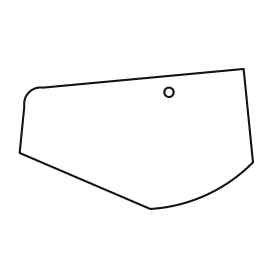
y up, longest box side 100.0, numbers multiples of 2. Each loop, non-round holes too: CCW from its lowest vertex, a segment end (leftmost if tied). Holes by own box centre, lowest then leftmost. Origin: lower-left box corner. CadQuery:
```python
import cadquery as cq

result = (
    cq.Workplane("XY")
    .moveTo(56.0, 0.0)
    .threePointArc((80.0, 6.0), (100.0, 20.0))
    .lineTo(96.0, 60.0)
    .lineTo(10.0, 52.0)
    .threePointArc((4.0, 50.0), (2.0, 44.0))
    .lineTo(0.0, 24.0)
    .close()
    .moveTo(64.0, 50.0)
    .circle(2.0)
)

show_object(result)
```